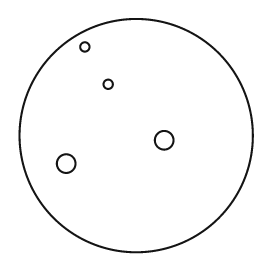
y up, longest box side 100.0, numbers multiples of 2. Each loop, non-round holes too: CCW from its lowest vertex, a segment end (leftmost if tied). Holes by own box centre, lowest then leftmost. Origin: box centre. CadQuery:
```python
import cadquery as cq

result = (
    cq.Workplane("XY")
    .moveTo(0.0, 0.0)
    .circle(50.0)
    .moveTo(-30.0, -12.0)
    .circle(4.0)
    .moveTo(12.0, -2.0)
    .circle(4.0)
    .moveTo(-12.0, 22.0)
    .circle(2.0)
    .moveTo(-22.0, 38.0)
    .circle(2.0)
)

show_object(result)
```